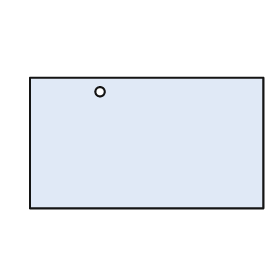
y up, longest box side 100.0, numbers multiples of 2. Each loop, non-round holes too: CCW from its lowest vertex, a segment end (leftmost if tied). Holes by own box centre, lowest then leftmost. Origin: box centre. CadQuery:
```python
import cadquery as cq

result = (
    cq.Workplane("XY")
    .moveTo(-50.0, -28.0)
    .lineTo(50.0, -28.0)
    .lineTo(50.0, 28.0)
    .lineTo(-50.0, 28.0)
    .close()
    .moveTo(-20.0, 22.0)
    .circle(2.0)
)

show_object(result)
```